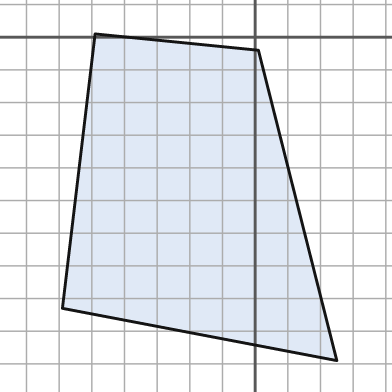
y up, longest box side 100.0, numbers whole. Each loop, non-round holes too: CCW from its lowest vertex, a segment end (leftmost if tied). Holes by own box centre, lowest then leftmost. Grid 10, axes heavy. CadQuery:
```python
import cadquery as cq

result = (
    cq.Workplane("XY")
    .moveTo(25.0, -99.0)
    .lineTo(1.0, -4.0)
    .lineTo(-49.0, 1.0)
    .lineTo(-59.0, -83.0)
    .close()
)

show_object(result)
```